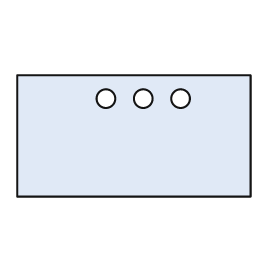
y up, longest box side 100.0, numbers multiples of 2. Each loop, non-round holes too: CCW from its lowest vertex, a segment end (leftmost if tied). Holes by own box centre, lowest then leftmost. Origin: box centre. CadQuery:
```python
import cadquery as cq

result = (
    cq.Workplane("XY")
    .moveTo(-50.0, -26.0)
    .lineTo(50.0, -26.0)
    .lineTo(50.0, 26.0)
    .lineTo(-50.0, 26.0)
    .close()
    .moveTo(-12.0, 16.0)
    .circle(4.0)
    .moveTo(4.0, 16.0)
    .circle(4.0)
    .moveTo(20.0, 16.0)
    .circle(4.0)
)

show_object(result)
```